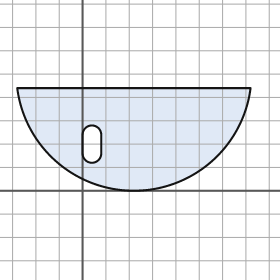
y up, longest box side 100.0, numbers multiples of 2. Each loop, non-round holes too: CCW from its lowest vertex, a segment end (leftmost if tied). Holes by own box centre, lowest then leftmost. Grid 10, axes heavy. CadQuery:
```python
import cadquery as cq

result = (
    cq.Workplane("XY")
    .moveTo(-28.0, 44.0)
    .threePointArc((22.0, 0.0), (72.0, 44.0))
    .close()
    .moveTo(0.0, 16.0)
    .threePointArc((4.0, 12.0), (8.0, 16.0))
    .lineTo(8.0, 24.0)
    .threePointArc((4.0, 28.0), (0.0, 24.0))
    .close()
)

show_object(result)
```